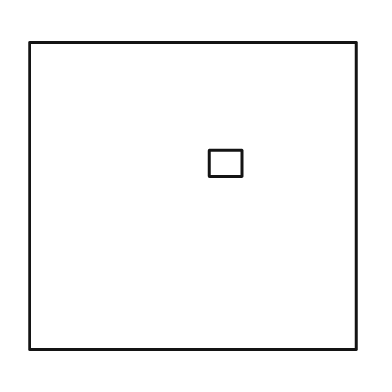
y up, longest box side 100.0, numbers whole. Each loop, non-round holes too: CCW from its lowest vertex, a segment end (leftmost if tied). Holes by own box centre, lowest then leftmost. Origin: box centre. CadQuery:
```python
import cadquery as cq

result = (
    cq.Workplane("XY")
    .moveTo(-50.0, -47.0)
    .lineTo(50.0, -47.0)
    .lineTo(50.0, 47.0)
    .lineTo(-50.0, 47.0)
    .close()
    .moveTo(5.0, 6.0)
    .lineTo(15.0, 6.0)
    .lineTo(15.0, 14.0)
    .lineTo(5.0, 14.0)
    .close()
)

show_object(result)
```